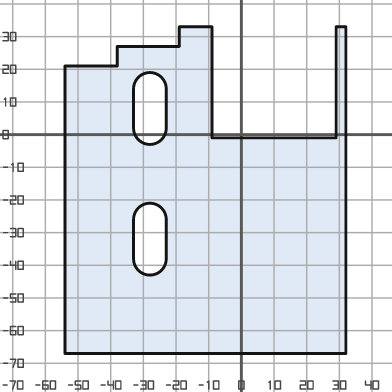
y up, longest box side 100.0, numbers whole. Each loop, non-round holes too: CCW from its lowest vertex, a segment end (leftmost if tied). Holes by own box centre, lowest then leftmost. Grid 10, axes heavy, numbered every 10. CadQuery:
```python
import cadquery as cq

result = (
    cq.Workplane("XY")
    .moveTo(-54.0, -67.0)
    .lineTo(32.0, -67.0)
    .lineTo(32.0, 33.0)
    .lineTo(29.0, 33.0)
    .lineTo(29.0, -1.0)
    .lineTo(-9.0, -1.0)
    .lineTo(-9.0, 33.0)
    .lineTo(-19.0, 33.0)
    .lineTo(-19.0, 27.0)
    .lineTo(-38.0, 27.0)
    .lineTo(-38.0, 21.0)
    .lineTo(-54.0, 21.0)
    .close()
    .moveTo(-33.0, -38.0)
    .threePointArc((-28.0, -43.0), (-23.0, -38.0))
    .lineTo(-23.0, -26.0)
    .threePointArc((-28.0, -21.0), (-33.0, -26.0))
    .close()
    .moveTo(-33.0, 2.0)
    .threePointArc((-28.0, -3.0), (-23.0, 2.0))
    .lineTo(-23.0, 14.0)
    .threePointArc((-28.0, 19.0), (-33.0, 14.0))
    .close()
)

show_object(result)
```